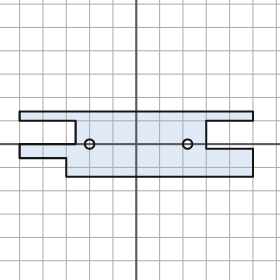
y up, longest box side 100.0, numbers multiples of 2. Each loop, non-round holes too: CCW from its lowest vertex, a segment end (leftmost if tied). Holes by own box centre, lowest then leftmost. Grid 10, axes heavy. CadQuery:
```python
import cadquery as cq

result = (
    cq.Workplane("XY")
    .moveTo(-30.0, -14.0)
    .lineTo(50.0, -14.0)
    .lineTo(50.0, -2.0)
    .lineTo(30.0, -2.0)
    .lineTo(30.0, 10.0)
    .lineTo(50.0, 10.0)
    .lineTo(50.0, 14.0)
    .lineTo(-50.0, 14.0)
    .lineTo(-50.0, 10.0)
    .lineTo(-26.0, 10.0)
    .lineTo(-26.0, 0.0)
    .lineTo(-50.0, 0.0)
    .lineTo(-50.0, -6.0)
    .lineTo(-30.0, -6.0)
    .close()
    .moveTo(-20.0, 0.0)
    .circle(2.0)
    .moveTo(22.0, 0.0)
    .circle(2.0)
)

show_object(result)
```